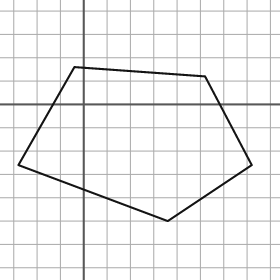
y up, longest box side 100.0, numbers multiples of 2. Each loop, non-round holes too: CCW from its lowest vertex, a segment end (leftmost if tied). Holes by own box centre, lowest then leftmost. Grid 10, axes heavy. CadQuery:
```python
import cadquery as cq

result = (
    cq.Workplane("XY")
    .moveTo(36.0, -50.0)
    .lineTo(72.0, -26.0)
    .lineTo(52.0, 12.0)
    .lineTo(-4.0, 16.0)
    .lineTo(-28.0, -26.0)
    .close()
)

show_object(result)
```